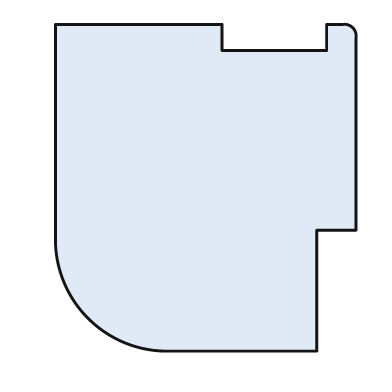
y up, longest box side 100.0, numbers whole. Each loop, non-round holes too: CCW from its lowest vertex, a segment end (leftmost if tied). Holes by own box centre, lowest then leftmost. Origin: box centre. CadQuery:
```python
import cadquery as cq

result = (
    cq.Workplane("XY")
    .moveTo(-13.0, -50.0)
    .lineTo(34.0, -50.0)
    .lineTo(34.0, -13.0)
    .lineTo(46.0, -13.0)
    .lineTo(46.0, 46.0)
    .threePointArc((45.0, 49.0), (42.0, 50.0))
    .lineTo(37.0, 50.0)
    .lineTo(37.0, 42.0)
    .lineTo(5.0, 42.0)
    .lineTo(5.0, 50.0)
    .lineTo(-46.0, 50.0)
    .lineTo(-46.0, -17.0)
    .threePointArc((-36.0, -40.0), (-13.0, -50.0))
    .close()
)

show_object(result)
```